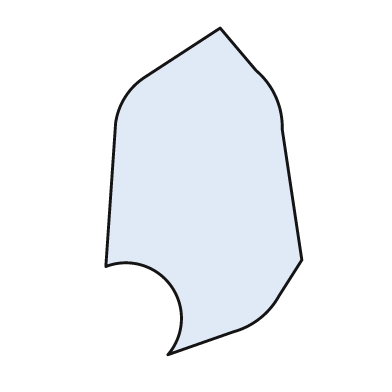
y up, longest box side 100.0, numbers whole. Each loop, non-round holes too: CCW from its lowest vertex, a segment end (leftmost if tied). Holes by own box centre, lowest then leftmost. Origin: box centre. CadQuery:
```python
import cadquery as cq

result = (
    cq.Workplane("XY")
    .moveTo(-11.0, -50.0)
    .lineTo(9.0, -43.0)
    .threePointArc((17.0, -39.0), (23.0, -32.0))
    .lineTo(30.0, -21.0)
    .lineTo(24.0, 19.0)
    .threePointArc((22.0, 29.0), (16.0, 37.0))
    .lineTo(5.0, 50.0)
    .lineTo(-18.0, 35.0)
    .threePointArc((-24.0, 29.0), (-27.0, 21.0))
    .lineTo(-30.0, -23.0)
    .threePointArc((-10.0, -29.0), (-11.0, -50.0))
    .close()
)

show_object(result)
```